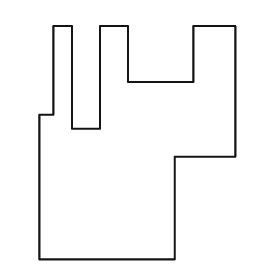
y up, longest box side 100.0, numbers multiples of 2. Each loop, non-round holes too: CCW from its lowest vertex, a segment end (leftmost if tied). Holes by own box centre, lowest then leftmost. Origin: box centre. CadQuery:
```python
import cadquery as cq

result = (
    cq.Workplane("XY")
    .moveTo(-42.0, -50.0)
    .lineTo(16.0, -50.0)
    .lineTo(16.0, -6.0)
    .lineTo(42.0, -6.0)
    .lineTo(42.0, 50.0)
    .lineTo(24.0, 50.0)
    .lineTo(24.0, 26.0)
    .lineTo(-4.0, 26.0)
    .lineTo(-4.0, 50.0)
    .lineTo(-16.0, 50.0)
    .lineTo(-16.0, 6.0)
    .lineTo(-28.0, 6.0)
    .lineTo(-28.0, 50.0)
    .lineTo(-36.0, 50.0)
    .lineTo(-36.0, 12.0)
    .lineTo(-42.0, 12.0)
    .close()
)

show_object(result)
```